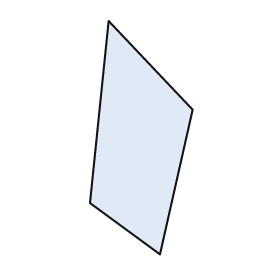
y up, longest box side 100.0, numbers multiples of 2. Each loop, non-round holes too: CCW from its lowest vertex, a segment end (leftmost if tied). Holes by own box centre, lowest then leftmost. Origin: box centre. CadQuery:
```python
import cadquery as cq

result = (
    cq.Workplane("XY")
    .moveTo(8.0, -50.0)
    .lineTo(22.0, 12.0)
    .lineTo(-14.0, 50.0)
    .lineTo(-22.0, -28.0)
    .close()
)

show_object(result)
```